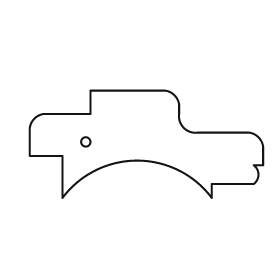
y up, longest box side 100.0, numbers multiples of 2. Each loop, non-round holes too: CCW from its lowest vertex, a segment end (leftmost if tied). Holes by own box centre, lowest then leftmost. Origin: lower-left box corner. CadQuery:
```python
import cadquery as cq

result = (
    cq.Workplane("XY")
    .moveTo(14.0, 0.0)
    .threePointArc((46.0, 16.0), (78.0, 0.0))
    .lineTo(78.0, 6.0)
    .lineTo(96.0, 6.0)
    .threePointArc((98.0, 10.0), (96.0, 14.0))
    .lineTo(100.0, 14.0)
    .lineTo(100.0, 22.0)
    .threePointArc((98.0, 26.0), (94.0, 28.0))
    .lineTo(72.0, 28.0)
    .threePointArc((66.0, 30.0), (64.0, 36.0))
    .lineTo(64.0, 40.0)
    .threePointArc((62.0, 44.0), (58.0, 46.0))
    .lineTo(26.0, 46.0)
    .lineTo(26.0, 36.0)
    .lineTo(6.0, 36.0)
    .threePointArc((2.0, 34.0), (0.0, 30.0))
    .lineTo(0.0, 18.0)
    .lineTo(14.0, 18.0)
    .close()
    .moveTo(24.0, 24.0)
    .circle(2.0)
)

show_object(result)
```